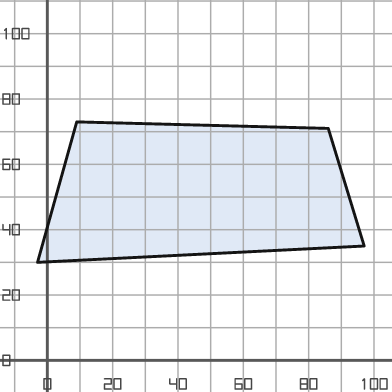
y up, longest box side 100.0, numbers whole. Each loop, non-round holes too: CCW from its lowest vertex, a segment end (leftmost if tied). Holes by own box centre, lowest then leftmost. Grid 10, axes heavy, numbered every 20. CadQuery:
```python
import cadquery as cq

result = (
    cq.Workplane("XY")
    .moveTo(-3.0, 30.0)
    .lineTo(97.0, 35.0)
    .lineTo(86.0, 71.0)
    .lineTo(9.0, 73.0)
    .close()
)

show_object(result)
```